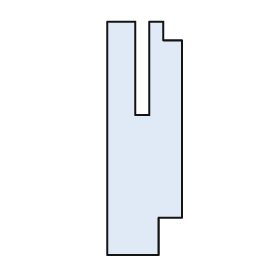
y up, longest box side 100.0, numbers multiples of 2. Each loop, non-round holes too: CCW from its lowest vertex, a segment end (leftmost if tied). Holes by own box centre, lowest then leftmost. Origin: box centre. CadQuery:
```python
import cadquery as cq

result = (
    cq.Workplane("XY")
    .moveTo(-16.0, -50.0)
    .lineTo(6.0, -50.0)
    .lineTo(6.0, -34.0)
    .lineTo(16.0, -34.0)
    .lineTo(16.0, 42.0)
    .lineTo(8.0, 42.0)
    .lineTo(8.0, 50.0)
    .lineTo(2.0, 50.0)
    .lineTo(2.0, 10.0)
    .lineTo(-4.0, 10.0)
    .lineTo(-4.0, 50.0)
    .lineTo(-16.0, 50.0)
    .close()
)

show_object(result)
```